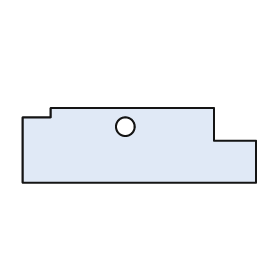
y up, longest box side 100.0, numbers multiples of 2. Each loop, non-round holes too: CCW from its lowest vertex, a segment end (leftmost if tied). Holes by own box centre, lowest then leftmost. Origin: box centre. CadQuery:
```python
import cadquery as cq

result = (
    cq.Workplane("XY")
    .moveTo(-50.0, -16.0)
    .lineTo(50.0, -16.0)
    .lineTo(50.0, 2.0)
    .lineTo(32.0, 2.0)
    .lineTo(32.0, 16.0)
    .lineTo(-38.0, 16.0)
    .lineTo(-38.0, 12.0)
    .lineTo(-50.0, 12.0)
    .close()
    .moveTo(-6.0, 8.0)
    .circle(4.0)
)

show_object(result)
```